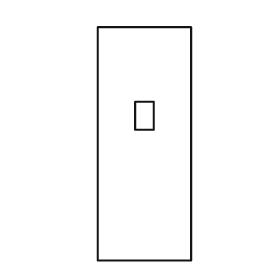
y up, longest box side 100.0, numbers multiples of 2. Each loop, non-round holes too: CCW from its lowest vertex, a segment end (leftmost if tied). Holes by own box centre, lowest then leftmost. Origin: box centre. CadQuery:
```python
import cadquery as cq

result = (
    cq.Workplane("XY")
    .moveTo(-20.0, -50.0)
    .lineTo(20.0, -50.0)
    .lineTo(20.0, 50.0)
    .lineTo(-20.0, 50.0)
    .close()
    .moveTo(-4.0, 6.0)
    .lineTo(4.0, 6.0)
    .lineTo(4.0, 18.0)
    .lineTo(-4.0, 18.0)
    .close()
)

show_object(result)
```